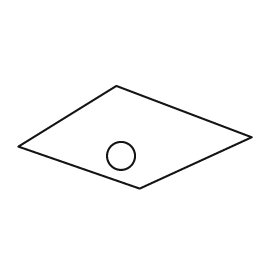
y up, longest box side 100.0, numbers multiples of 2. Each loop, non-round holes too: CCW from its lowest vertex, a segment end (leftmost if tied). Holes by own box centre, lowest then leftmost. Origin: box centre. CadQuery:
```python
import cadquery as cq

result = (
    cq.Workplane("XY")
    .moveTo(2.0, -22.0)
    .lineTo(50.0, 0.0)
    .lineTo(-8.0, 22.0)
    .lineTo(-50.0, -4.0)
    .close()
    .moveTo(-6.0, -8.0)
    .circle(6.0)
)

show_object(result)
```